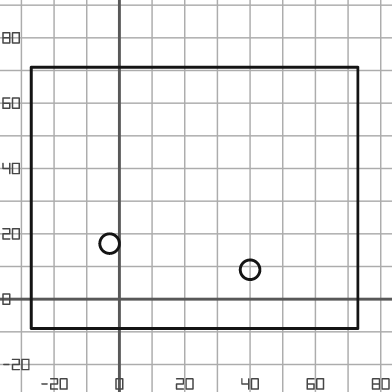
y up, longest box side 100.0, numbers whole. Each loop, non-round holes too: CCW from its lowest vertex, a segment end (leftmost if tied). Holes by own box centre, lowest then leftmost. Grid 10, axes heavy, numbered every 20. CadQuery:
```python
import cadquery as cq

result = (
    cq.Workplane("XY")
    .moveTo(-27.0, -9.0)
    .lineTo(73.0, -9.0)
    .lineTo(73.0, 71.0)
    .lineTo(-27.0, 71.0)
    .close()
    .moveTo(40.0, 9.0)
    .circle(3.0)
    .moveTo(-3.0, 17.0)
    .circle(3.0)
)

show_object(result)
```